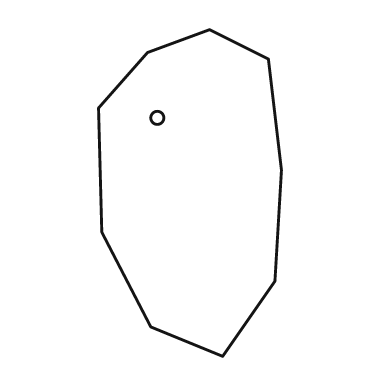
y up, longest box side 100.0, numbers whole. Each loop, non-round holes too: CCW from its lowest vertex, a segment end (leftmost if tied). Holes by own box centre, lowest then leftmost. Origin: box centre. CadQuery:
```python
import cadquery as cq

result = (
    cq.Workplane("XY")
    .moveTo(10.0, -50.0)
    .lineTo(26.0, -27.0)
    .lineTo(28.0, 7.0)
    .lineTo(24.0, 41.0)
    .lineTo(6.0, 50.0)
    .lineTo(-13.0, 43.0)
    .lineTo(-28.0, 26.0)
    .lineTo(-27.0, -12.0)
    .lineTo(-12.0, -41.0)
    .close()
    .moveTo(-10.0, 23.0)
    .circle(2.0)
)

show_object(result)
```